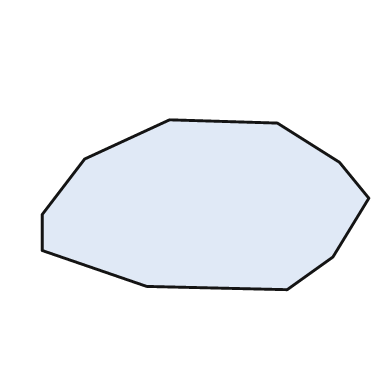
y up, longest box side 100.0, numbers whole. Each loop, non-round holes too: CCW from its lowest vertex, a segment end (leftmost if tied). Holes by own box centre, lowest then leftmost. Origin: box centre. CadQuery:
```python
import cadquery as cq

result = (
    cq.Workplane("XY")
    .moveTo(25.0, -26.0)
    .lineTo(39.0, -16.0)
    .lineTo(50.0, 2.0)
    .lineTo(41.0, 13.0)
    .lineTo(22.0, 25.0)
    .lineTo(-11.0, 26.0)
    .lineTo(-37.0, 14.0)
    .lineTo(-50.0, -3.0)
    .lineTo(-50.0, -14.0)
    .lineTo(-18.0, -25.0)
    .close()
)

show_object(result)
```